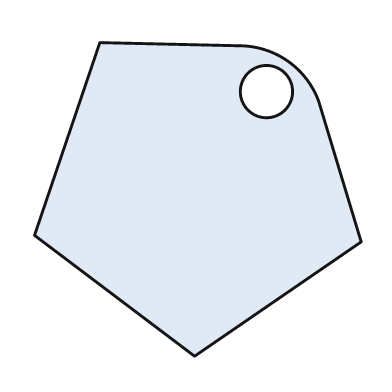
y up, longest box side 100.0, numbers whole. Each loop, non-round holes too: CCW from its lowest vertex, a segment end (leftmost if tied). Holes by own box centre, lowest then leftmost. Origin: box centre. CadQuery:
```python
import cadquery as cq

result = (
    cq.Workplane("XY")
    .moveTo(-1.0, -48.0)
    .lineTo(50.0, -13.0)
    .lineTo(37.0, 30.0)
    .threePointArc((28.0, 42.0), (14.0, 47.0))
    .lineTo(-30.0, 48.0)
    .lineTo(-50.0, -11.0)
    .close()
    .moveTo(21.0, 33.0)
    .circle(8.0)
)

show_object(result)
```